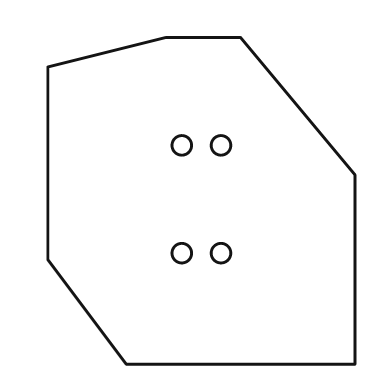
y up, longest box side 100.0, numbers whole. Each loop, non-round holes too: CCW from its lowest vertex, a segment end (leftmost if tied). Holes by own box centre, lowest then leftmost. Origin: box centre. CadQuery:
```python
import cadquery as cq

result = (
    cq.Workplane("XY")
    .moveTo(-23.0, -50.0)
    .lineTo(47.0, -50.0)
    .lineTo(47.0, 8.0)
    .lineTo(12.0, 50.0)
    .lineTo(-11.0, 50.0)
    .lineTo(-47.0, 41.0)
    .lineTo(-47.0, -18.0)
    .close()
    .moveTo(-6.0, -16.0)
    .circle(3.0)
    .moveTo(6.0, -16.0)
    .circle(3.0)
    .moveTo(-6.0, 17.0)
    .circle(3.0)
    .moveTo(6.0, 17.0)
    .circle(3.0)
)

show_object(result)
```